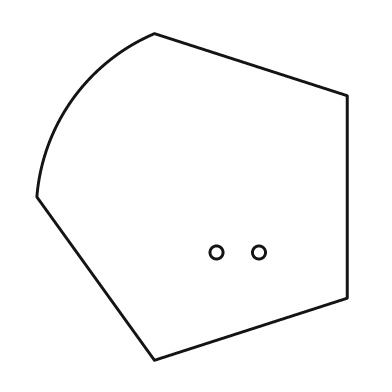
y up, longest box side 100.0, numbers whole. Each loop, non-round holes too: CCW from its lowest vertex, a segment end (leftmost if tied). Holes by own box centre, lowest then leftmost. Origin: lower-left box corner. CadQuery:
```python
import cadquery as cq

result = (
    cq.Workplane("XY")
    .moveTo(36.0, 0.0)
    .lineTo(95.0, 19.0)
    .lineTo(95.0, 81.0)
    .lineTo(36.0, 100.0)
    .threePointArc((11.0, 80.0), (0.0, 50.0))
    .close()
    .moveTo(55.0, 33.0)
    .circle(2.0)
    .moveTo(68.0, 33.0)
    .circle(2.0)
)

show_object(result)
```